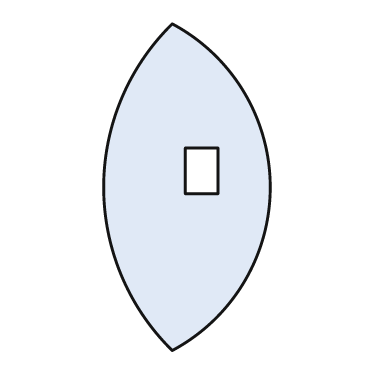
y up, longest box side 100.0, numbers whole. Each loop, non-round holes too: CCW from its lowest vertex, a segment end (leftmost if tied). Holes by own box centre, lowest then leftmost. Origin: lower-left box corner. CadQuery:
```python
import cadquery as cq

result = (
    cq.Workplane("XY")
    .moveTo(21.0, 0.0)
    .threePointArc((51.0, 50.0), (21.0, 100.0))
    .threePointArc((0.0, 50.0), (21.0, 0.0))
    .close()
    .moveTo(25.0, 48.0)
    .lineTo(35.0, 48.0)
    .lineTo(35.0, 62.0)
    .lineTo(25.0, 62.0)
    .close()
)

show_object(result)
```